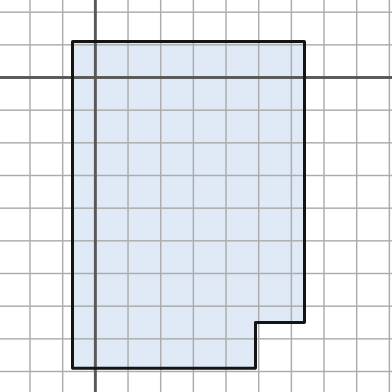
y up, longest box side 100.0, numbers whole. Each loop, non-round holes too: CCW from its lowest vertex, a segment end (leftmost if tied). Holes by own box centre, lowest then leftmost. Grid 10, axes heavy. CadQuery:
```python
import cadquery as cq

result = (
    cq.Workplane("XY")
    .moveTo(-7.0, -89.0)
    .lineTo(49.0, -89.0)
    .lineTo(49.0, -75.0)
    .lineTo(64.0, -75.0)
    .lineTo(64.0, 11.0)
    .lineTo(-7.0, 11.0)
    .close()
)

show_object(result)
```